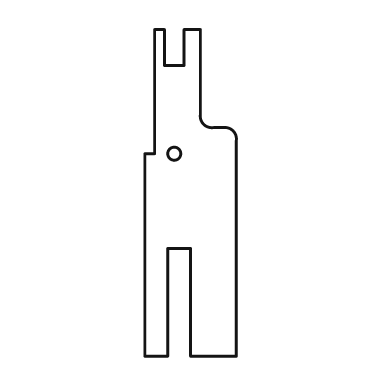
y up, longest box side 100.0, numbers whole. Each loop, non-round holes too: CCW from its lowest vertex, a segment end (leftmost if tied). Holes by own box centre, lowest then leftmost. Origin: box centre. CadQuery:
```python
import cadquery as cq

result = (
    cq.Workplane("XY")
    .moveTo(-14.0, -50.0)
    .lineTo(-7.0, -50.0)
    .lineTo(-7.0, -17.0)
    .lineTo(0.0, -17.0)
    .lineTo(0.0, -50.0)
    .lineTo(14.0, -50.0)
    .lineTo(14.0, 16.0)
    .threePointArc((13.0, 19.0), (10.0, 20.0))
    .lineTo(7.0, 20.0)
    .threePointArc((4.0, 21.0), (3.0, 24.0))
    .lineTo(3.0, 50.0)
    .lineTo(-2.0, 50.0)
    .lineTo(-2.0, 39.0)
    .lineTo(-8.0, 39.0)
    .lineTo(-8.0, 50.0)
    .lineTo(-11.0, 50.0)
    .lineTo(-11.0, 12.0)
    .lineTo(-14.0, 12.0)
    .close()
    .moveTo(-5.0, 12.0)
    .circle(2.0)
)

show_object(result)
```